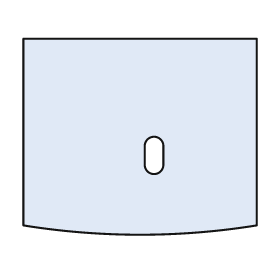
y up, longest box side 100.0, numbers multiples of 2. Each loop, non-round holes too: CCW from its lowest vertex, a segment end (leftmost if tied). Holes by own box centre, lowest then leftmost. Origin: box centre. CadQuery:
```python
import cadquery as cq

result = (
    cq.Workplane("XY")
    .moveTo(-50.0, -38.0)
    .threePointArc((0.0, -42.0), (50.0, -38.0))
    .lineTo(50.0, 42.0)
    .lineTo(-50.0, 42.0)
    .close()
    .moveTo(2.0, -12.0)
    .threePointArc((6.0, -16.0), (10.0, -12.0))
    .lineTo(10.0, -4.0)
    .threePointArc((6.0, 0.0), (2.0, -4.0))
    .close()
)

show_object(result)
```